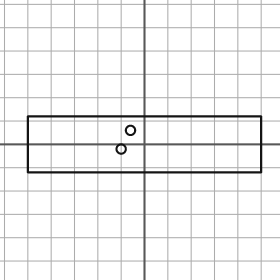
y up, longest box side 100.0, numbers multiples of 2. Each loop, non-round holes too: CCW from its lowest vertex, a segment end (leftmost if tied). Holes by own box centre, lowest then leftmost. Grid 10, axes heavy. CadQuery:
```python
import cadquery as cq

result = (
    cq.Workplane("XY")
    .moveTo(-50.0, -12.0)
    .lineTo(50.0, -12.0)
    .lineTo(50.0, 12.0)
    .lineTo(-50.0, 12.0)
    .close()
    .moveTo(-10.0, -2.0)
    .circle(2.0)
    .moveTo(-6.0, 6.0)
    .circle(2.0)
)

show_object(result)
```